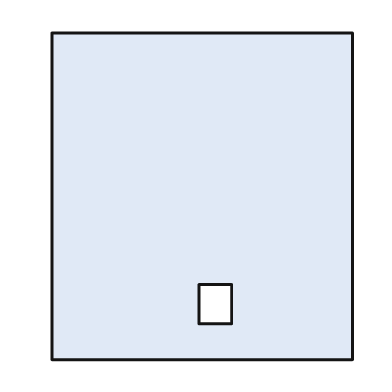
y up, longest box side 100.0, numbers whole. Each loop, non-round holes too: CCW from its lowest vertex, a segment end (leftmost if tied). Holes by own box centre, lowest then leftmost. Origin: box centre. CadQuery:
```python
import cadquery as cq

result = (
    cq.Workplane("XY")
    .moveTo(-46.0, -50.0)
    .lineTo(46.0, -50.0)
    .lineTo(46.0, 50.0)
    .lineTo(-46.0, 50.0)
    .close()
    .moveTo(-1.0, -39.0)
    .lineTo(9.0, -39.0)
    .lineTo(9.0, -27.0)
    .lineTo(-1.0, -27.0)
    .close()
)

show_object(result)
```